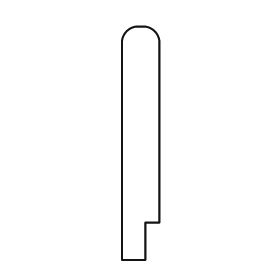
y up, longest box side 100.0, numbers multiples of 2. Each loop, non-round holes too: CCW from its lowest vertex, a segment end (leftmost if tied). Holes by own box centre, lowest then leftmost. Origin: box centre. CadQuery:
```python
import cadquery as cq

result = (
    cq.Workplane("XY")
    .moveTo(-8.0, -50.0)
    .lineTo(2.0, -50.0)
    .lineTo(2.0, -34.0)
    .lineTo(8.0, -34.0)
    .lineTo(8.0, 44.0)
    .threePointArc((6.0, 48.0), (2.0, 50.0))
    .lineTo(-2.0, 50.0)
    .threePointArc((-6.0, 48.0), (-8.0, 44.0))
    .close()
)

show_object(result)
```